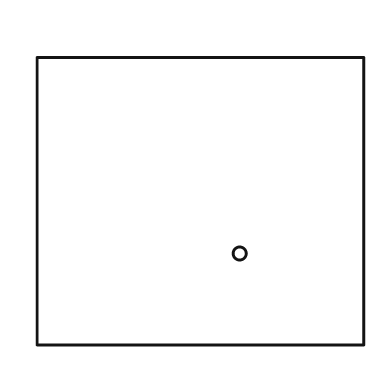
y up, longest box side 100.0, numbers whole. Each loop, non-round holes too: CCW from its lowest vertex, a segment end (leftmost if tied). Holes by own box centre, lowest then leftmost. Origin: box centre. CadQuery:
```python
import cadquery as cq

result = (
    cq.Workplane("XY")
    .moveTo(-50.0, -44.0)
    .lineTo(50.0, -44.0)
    .lineTo(50.0, 44.0)
    .lineTo(-50.0, 44.0)
    .close()
    .moveTo(12.0, -16.0)
    .circle(2.0)
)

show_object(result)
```